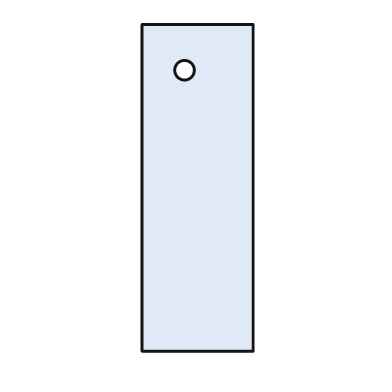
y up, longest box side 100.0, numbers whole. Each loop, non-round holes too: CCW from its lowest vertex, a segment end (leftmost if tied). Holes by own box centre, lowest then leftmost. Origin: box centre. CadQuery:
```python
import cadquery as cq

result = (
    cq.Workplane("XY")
    .moveTo(-17.0, -50.0)
    .lineTo(17.0, -50.0)
    .lineTo(17.0, 50.0)
    .lineTo(-17.0, 50.0)
    .close()
    .moveTo(-4.0, 36.0)
    .circle(3.0)
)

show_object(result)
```